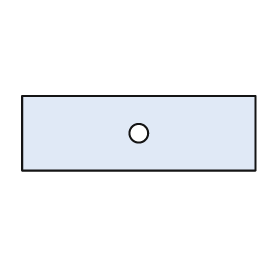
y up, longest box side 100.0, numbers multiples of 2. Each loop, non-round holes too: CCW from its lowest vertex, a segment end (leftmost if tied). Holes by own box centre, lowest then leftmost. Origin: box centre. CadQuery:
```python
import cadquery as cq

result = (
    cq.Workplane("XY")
    .moveTo(-50.0, -16.0)
    .lineTo(50.0, -16.0)
    .lineTo(50.0, 16.0)
    .lineTo(-50.0, 16.0)
    .close()
    .moveTo(0.0, 0.0)
    .circle(4.0)
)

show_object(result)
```